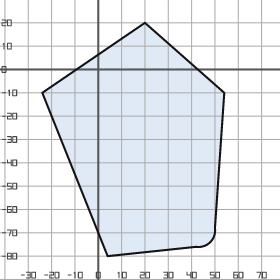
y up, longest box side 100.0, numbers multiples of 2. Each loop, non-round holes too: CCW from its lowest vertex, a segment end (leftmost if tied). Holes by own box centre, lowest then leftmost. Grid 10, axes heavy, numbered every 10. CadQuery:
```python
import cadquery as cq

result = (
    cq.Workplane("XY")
    .moveTo(4.0, -80.0)
    .lineTo(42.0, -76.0)
    .threePointArc((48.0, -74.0), (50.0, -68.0))
    .lineTo(54.0, -10.0)
    .lineTo(20.0, 20.0)
    .lineTo(-24.0, -10.0)
    .close()
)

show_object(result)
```